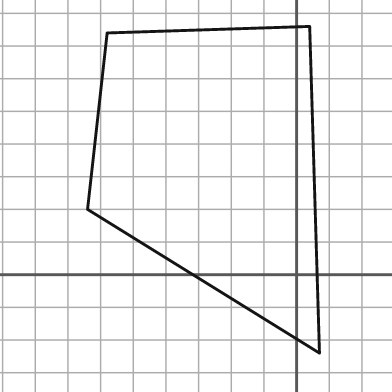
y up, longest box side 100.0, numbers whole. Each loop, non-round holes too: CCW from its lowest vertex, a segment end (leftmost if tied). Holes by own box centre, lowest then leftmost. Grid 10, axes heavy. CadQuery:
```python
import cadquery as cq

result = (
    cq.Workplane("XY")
    .moveTo(7.0, -24.0)
    .lineTo(4.0, 76.0)
    .lineTo(-58.0, 74.0)
    .lineTo(-64.0, 20.0)
    .close()
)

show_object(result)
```